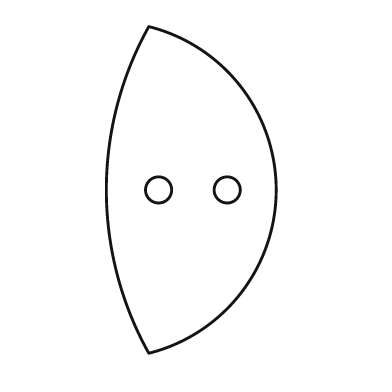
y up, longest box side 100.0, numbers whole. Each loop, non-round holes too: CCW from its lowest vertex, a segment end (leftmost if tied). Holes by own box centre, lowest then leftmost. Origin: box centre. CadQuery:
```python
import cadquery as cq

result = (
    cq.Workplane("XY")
    .moveTo(-13.0, -50.0)
    .threePointArc((26.0, 0.0), (-13.0, 50.0))
    .threePointArc((-26.0, 0.0), (-13.0, -50.0))
    .close()
    .moveTo(-10.0, 0.0)
    .circle(4.0)
    .moveTo(11.0, 0.0)
    .circle(4.0)
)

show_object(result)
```